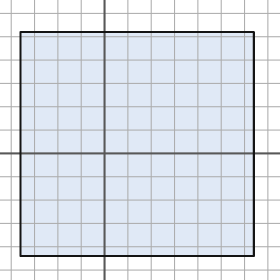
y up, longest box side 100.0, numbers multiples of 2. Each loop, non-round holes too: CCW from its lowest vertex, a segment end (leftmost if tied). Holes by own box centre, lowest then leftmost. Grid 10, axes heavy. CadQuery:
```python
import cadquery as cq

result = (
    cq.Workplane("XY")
    .moveTo(-36.0, -44.0)
    .lineTo(64.0, -44.0)
    .lineTo(64.0, 52.0)
    .lineTo(-36.0, 52.0)
    .close()
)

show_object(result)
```